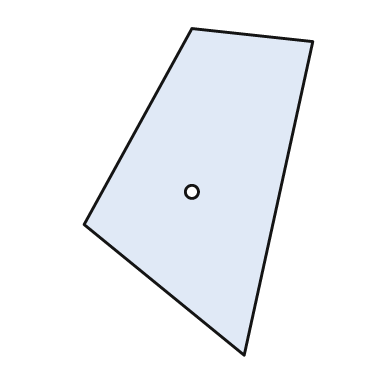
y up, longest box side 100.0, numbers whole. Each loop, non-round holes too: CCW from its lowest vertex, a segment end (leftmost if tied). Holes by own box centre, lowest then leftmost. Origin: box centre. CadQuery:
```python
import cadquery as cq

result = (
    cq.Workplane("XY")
    .moveTo(14.0, -50.0)
    .lineTo(35.0, 46.0)
    .lineTo(-2.0, 50.0)
    .lineTo(-35.0, -10.0)
    .close()
    .moveTo(-2.0, 0.0)
    .circle(2.0)
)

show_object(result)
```